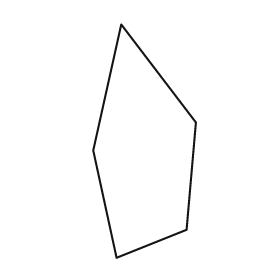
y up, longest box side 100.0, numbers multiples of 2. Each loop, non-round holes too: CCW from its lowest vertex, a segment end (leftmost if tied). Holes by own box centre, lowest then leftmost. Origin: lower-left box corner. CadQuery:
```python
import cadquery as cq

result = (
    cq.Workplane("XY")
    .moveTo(10.0, 0.0)
    .lineTo(40.0, 12.0)
    .lineTo(44.0, 58.0)
    .lineTo(12.0, 100.0)
    .lineTo(0.0, 46.0)
    .close()
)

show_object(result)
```